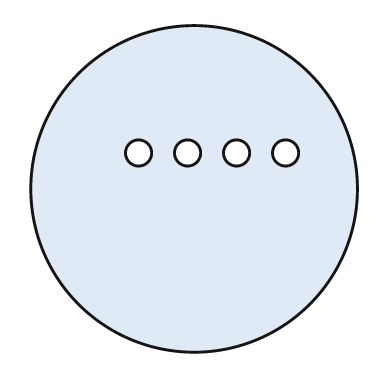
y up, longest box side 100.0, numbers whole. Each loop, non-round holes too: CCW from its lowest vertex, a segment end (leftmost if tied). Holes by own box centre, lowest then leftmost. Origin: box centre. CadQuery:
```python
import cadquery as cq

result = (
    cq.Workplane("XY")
    .moveTo(0.0, 0.0)
    .circle(50.0)
    .moveTo(-17.0, 11.0)
    .circle(4.0)
    .moveTo(-2.0, 11.0)
    .circle(4.0)
    .moveTo(13.0, 11.0)
    .circle(4.0)
    .moveTo(28.0, 11.0)
    .circle(4.0)
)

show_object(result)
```